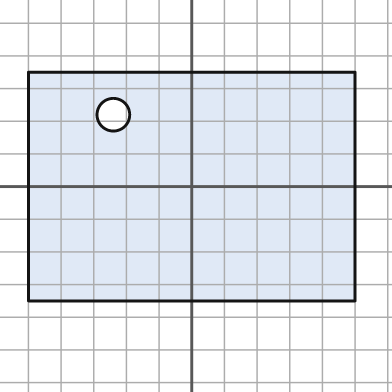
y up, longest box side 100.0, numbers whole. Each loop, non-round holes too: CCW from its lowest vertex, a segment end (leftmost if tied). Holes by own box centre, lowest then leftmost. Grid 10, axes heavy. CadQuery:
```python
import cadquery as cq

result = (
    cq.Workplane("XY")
    .moveTo(-50.0, -35.0)
    .lineTo(50.0, -35.0)
    .lineTo(50.0, 35.0)
    .lineTo(-50.0, 35.0)
    .close()
    .moveTo(-24.0, 22.0)
    .circle(5.0)
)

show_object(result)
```